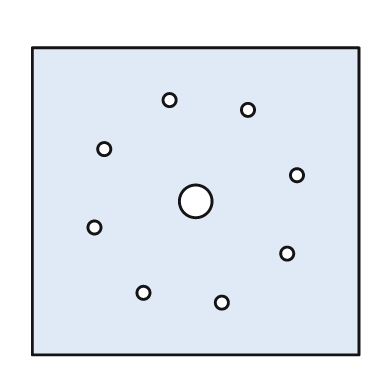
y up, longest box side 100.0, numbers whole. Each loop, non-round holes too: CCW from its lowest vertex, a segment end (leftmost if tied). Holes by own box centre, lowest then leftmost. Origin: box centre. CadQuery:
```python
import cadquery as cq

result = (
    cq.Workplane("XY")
    .moveTo(-50.0, -47.0)
    .lineTo(50.0, -47.0)
    .lineTo(50.0, 47.0)
    .lineTo(-50.0, 47.0)
    .close()
    .moveTo(8.0, -31.0)
    .circle(2.0)
    .moveTo(-16.0, -28.0)
    .circle(2.0)
    .moveTo(28.0, -16.0)
    .circle(2.0)
    .moveTo(-31.0, -8.0)
    .circle(2.0)
    .moveTo(0.0, 0.0)
    .circle(5.0)
    .moveTo(31.0, 8.0)
    .circle(2.0)
    .moveTo(-28.0, 16.0)
    .circle(2.0)
    .moveTo(16.0, 28.0)
    .circle(2.0)
    .moveTo(-8.0, 31.0)
    .circle(2.0)
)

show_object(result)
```